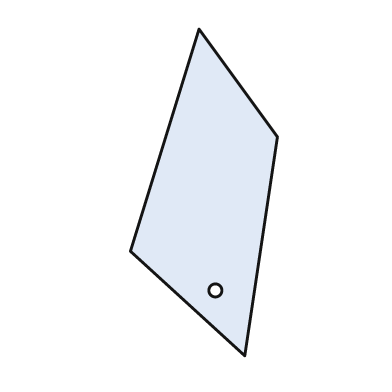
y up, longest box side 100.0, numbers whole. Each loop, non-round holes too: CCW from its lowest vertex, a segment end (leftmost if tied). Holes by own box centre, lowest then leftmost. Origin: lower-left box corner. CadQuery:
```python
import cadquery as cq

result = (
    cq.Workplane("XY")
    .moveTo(35.0, 0.0)
    .lineTo(45.0, 67.0)
    .lineTo(21.0, 100.0)
    .lineTo(0.0, 32.0)
    .close()
    .moveTo(26.0, 20.0)
    .circle(2.0)
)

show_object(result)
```